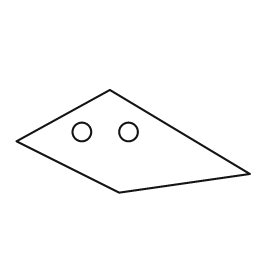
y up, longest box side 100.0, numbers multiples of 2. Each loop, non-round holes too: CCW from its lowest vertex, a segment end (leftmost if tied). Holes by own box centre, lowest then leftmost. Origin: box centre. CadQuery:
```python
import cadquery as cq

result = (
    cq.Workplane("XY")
    .moveTo(-6.0, -22.0)
    .lineTo(50.0, -14.0)
    .lineTo(-10.0, 22.0)
    .lineTo(-50.0, 0.0)
    .close()
    .moveTo(-22.0, 4.0)
    .circle(4.0)
    .moveTo(-2.0, 4.0)
    .circle(4.0)
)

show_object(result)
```